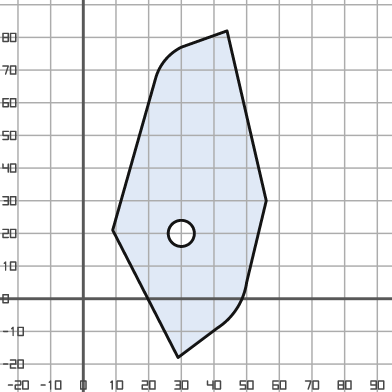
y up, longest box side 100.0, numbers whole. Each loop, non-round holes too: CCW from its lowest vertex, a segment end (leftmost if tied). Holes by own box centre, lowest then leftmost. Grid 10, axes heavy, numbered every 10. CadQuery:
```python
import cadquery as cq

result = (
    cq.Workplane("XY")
    .moveTo(29.0, -18.0)
    .lineTo(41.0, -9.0)
    .threePointArc((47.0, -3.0), (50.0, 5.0))
    .lineTo(56.0, 30.0)
    .lineTo(44.0, 82.0)
    .lineTo(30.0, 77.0)
    .threePointArc((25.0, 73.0), (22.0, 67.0))
    .lineTo(9.0, 21.0)
    .close()
    .moveTo(30.0, 20.0)
    .circle(4.0)
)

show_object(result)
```